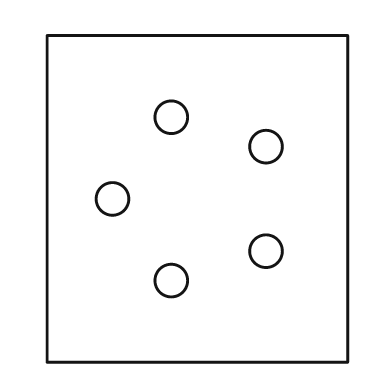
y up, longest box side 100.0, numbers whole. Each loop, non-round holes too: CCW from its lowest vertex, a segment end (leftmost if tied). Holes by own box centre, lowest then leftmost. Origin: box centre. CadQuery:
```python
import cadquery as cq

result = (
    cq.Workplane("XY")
    .moveTo(-46.0, -50.0)
    .lineTo(46.0, -50.0)
    .lineTo(46.0, 50.0)
    .lineTo(-46.0, 50.0)
    .close()
    .moveTo(-8.0, -25.0)
    .circle(5.0)
    .moveTo(21.0, -16.0)
    .circle(5.0)
    .moveTo(-26.0, 0.0)
    .circle(5.0)
    .moveTo(21.0, 16.0)
    .circle(5.0)
    .moveTo(-8.0, 25.0)
    .circle(5.0)
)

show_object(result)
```